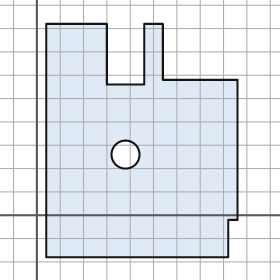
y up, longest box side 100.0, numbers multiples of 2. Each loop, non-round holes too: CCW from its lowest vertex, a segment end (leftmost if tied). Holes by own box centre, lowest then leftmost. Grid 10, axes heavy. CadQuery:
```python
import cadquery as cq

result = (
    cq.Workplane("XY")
    .moveTo(4.0, -18.0)
    .lineTo(82.0, -18.0)
    .lineTo(82.0, -2.0)
    .lineTo(86.0, -2.0)
    .lineTo(86.0, 58.0)
    .lineTo(54.0, 58.0)
    .lineTo(54.0, 82.0)
    .lineTo(46.0, 82.0)
    .lineTo(46.0, 56.0)
    .lineTo(30.0, 56.0)
    .lineTo(30.0, 82.0)
    .lineTo(4.0, 82.0)
    .close()
    .moveTo(38.0, 26.0)
    .circle(6.0)
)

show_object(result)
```